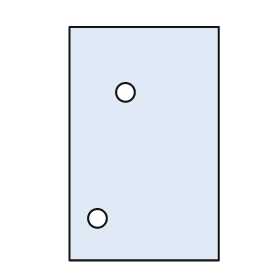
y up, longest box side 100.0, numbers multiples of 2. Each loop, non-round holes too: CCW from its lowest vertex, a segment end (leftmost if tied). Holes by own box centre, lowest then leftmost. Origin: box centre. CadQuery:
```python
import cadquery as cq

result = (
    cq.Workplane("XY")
    .moveTo(-32.0, -50.0)
    .lineTo(32.0, -50.0)
    .lineTo(32.0, 50.0)
    .lineTo(-32.0, 50.0)
    .close()
    .moveTo(-20.0, -32.0)
    .circle(4.0)
    .moveTo(-8.0, 22.0)
    .circle(4.0)
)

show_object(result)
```